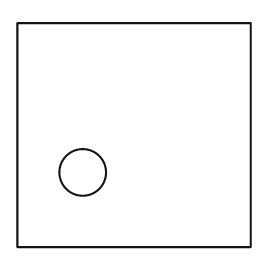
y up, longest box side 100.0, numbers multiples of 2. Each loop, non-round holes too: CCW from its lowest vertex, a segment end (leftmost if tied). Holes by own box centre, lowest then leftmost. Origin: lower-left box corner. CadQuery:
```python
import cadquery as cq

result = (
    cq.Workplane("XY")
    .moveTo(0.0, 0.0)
    .lineTo(100.0, 0.0)
    .lineTo(100.0, 96.0)
    .lineTo(0.0, 96.0)
    .close()
    .moveTo(28.0, 32.0)
    .circle(10.0)
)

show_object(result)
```